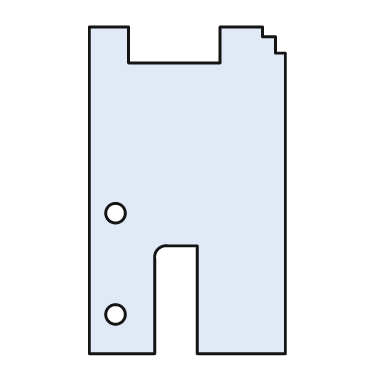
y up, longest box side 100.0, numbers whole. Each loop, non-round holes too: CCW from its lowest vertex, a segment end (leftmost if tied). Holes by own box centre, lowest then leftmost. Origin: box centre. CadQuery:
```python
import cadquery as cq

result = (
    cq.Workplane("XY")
    .moveTo(-30.0, -50.0)
    .lineTo(-10.0, -50.0)
    .lineTo(-10.0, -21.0)
    .threePointArc((-9.0, -18.0), (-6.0, -17.0))
    .lineTo(3.0, -17.0)
    .lineTo(3.0, -50.0)
    .lineTo(30.0, -50.0)
    .lineTo(30.0, 42.0)
    .lineTo(27.0, 42.0)
    .lineTo(27.0, 47.0)
    .lineTo(23.0, 47.0)
    .lineTo(23.0, 50.0)
    .lineTo(10.0, 50.0)
    .lineTo(10.0, 39.0)
    .lineTo(-18.0, 39.0)
    .lineTo(-18.0, 50.0)
    .lineTo(-30.0, 50.0)
    .close()
    .moveTo(-22.0, -38.0)
    .circle(3.0)
    .moveTo(-22.0, -7.0)
    .circle(3.0)
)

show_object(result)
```